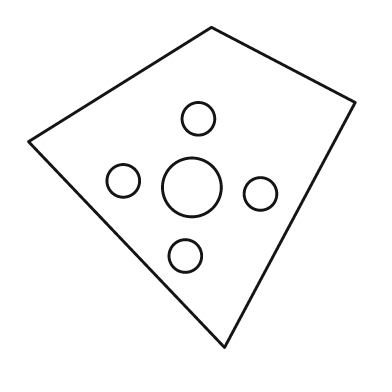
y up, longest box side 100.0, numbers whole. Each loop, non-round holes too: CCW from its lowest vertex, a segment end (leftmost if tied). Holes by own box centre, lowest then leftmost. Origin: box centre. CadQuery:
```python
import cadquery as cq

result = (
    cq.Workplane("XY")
    .moveTo(10.0, -49.0)
    .lineTo(50.0, 26.0)
    .lineTo(6.0, 49.0)
    .lineTo(-50.0, 14.0)
    .close()
    .moveTo(-2.0, -21.0)
    .circle(5.0)
    .moveTo(21.0, -2.0)
    .circle(5.0)
    .moveTo(0.0, 0.0)
    .circle(9.0)
    .moveTo(-21.0, 2.0)
    .circle(5.0)
    .moveTo(2.0, 21.0)
    .circle(5.0)
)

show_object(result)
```